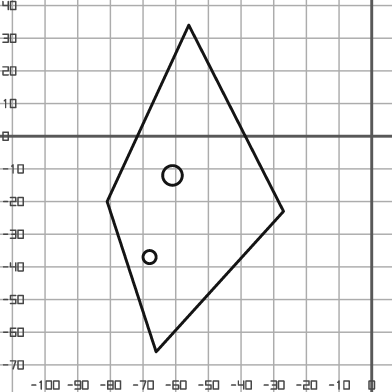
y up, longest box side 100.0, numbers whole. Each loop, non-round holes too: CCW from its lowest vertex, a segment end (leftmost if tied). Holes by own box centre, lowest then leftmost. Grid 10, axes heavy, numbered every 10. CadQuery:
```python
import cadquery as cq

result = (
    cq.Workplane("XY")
    .moveTo(-66.0, -66.0)
    .lineTo(-27.0, -23.0)
    .lineTo(-56.0, 34.0)
    .lineTo(-81.0, -20.0)
    .close()
    .moveTo(-68.0, -37.0)
    .circle(2.0)
    .moveTo(-61.0, -12.0)
    .circle(3.0)
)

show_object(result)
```